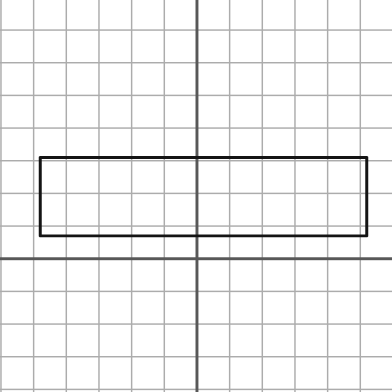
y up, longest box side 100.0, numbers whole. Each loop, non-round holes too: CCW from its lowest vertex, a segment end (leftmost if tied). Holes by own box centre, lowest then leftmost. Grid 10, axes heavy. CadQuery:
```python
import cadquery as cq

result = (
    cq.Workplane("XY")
    .moveTo(-48.0, 7.0)
    .lineTo(52.0, 7.0)
    .lineTo(52.0, 31.0)
    .lineTo(-48.0, 31.0)
    .close()
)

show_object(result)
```